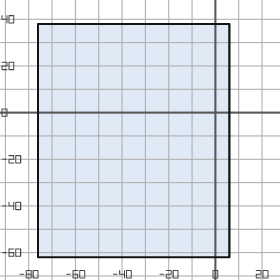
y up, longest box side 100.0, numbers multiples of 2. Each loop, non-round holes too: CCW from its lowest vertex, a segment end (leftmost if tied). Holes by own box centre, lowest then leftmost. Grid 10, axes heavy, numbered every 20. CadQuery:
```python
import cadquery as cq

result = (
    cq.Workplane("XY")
    .moveTo(-76.0, -62.0)
    .lineTo(6.0, -62.0)
    .lineTo(6.0, 38.0)
    .lineTo(-76.0, 38.0)
    .close()
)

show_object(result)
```